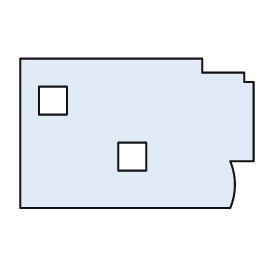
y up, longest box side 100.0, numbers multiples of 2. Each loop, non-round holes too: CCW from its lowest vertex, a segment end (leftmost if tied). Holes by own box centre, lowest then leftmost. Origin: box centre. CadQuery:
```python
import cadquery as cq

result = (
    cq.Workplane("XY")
    .moveTo(-50.0, -32.0)
    .lineTo(40.0, -32.0)
    .threePointArc((42.0, -22.0), (40.0, -12.0))
    .lineTo(50.0, -12.0)
    .lineTo(50.0, 22.0)
    .lineTo(46.0, 22.0)
    .lineTo(46.0, 26.0)
    .lineTo(28.0, 26.0)
    .lineTo(28.0, 32.0)
    .lineTo(-50.0, 32.0)
    .close()
    .moveTo(-8.0, -16.0)
    .lineTo(4.0, -16.0)
    .lineTo(4.0, -4.0)
    .lineTo(-8.0, -4.0)
    .close()
    .moveTo(-42.0, 8.0)
    .lineTo(-30.0, 8.0)
    .lineTo(-30.0, 20.0)
    .lineTo(-42.0, 20.0)
    .close()
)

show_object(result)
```